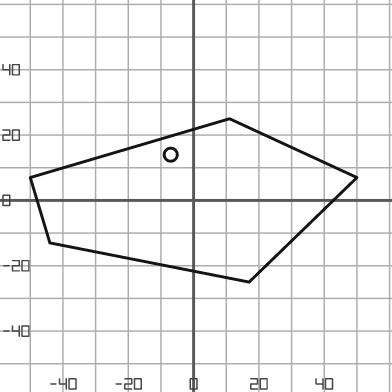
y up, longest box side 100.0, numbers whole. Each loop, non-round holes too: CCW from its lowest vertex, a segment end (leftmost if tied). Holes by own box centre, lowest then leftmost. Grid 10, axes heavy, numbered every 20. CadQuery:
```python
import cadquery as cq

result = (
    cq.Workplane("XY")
    .moveTo(17.0, -25.0)
    .lineTo(50.0, 7.0)
    .lineTo(11.0, 25.0)
    .lineTo(-50.0, 7.0)
    .lineTo(-44.0, -13.0)
    .close()
    .moveTo(-7.0, 14.0)
    .circle(2.0)
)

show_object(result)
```